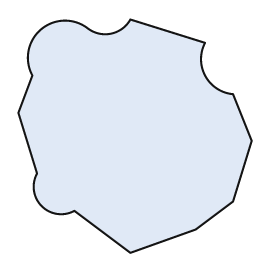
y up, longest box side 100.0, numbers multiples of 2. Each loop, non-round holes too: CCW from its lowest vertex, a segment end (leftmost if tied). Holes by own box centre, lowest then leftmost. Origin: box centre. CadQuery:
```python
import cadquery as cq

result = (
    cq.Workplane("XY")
    .moveTo(-2.0, -50.0)
    .lineTo(26.0, -40.0)
    .lineTo(42.0, -28.0)
    .lineTo(50.0, -2.0)
    .lineTo(42.0, 18.0)
    .threePointArc((30.0, 26.0), (30.0, 40.0))
    .lineTo(-2.0, 50.0)
    .threePointArc((-10.0, 44.0), (-20.0, 46.0))
    .threePointArc((-40.0, 46.0), (-44.0, 26.0))
    .lineTo(-50.0, 10.0)
    .lineTo(-42.0, -16.0)
    .threePointArc((-40.0, -30.0), (-26.0, -32.0))
    .close()
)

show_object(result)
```